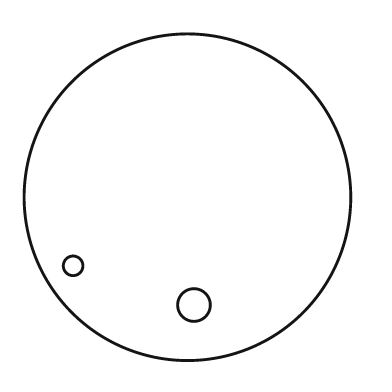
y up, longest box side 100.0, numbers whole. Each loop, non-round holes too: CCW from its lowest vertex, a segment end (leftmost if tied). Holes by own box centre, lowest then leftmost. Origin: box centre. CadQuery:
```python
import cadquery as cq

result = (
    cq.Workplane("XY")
    .moveTo(0.0, 0.0)
    .circle(50.0)
    .moveTo(2.0, -33.0)
    .circle(5.0)
    .moveTo(-35.0, -21.0)
    .circle(3.0)
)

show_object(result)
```